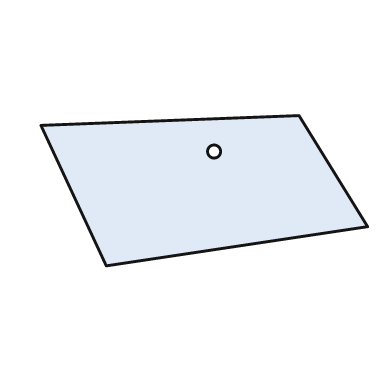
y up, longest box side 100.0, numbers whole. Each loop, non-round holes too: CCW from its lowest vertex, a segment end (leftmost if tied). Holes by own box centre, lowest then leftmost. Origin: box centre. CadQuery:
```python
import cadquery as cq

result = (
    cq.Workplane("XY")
    .moveTo(-30.0, -23.0)
    .lineTo(50.0, -11.0)
    .lineTo(29.0, 23.0)
    .lineTo(-50.0, 20.0)
    .close()
    .moveTo(3.0, 12.0)
    .circle(2.0)
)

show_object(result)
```